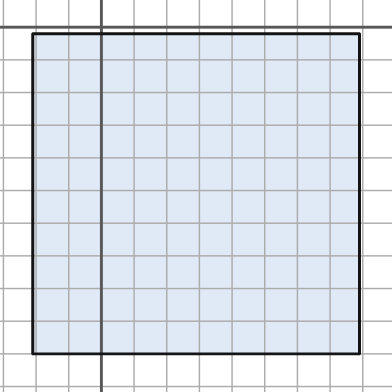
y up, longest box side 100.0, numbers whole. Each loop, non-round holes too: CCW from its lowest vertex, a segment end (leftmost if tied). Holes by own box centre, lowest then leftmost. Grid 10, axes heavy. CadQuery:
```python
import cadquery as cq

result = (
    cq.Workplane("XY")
    .moveTo(-21.0, -100.0)
    .lineTo(79.0, -100.0)
    .lineTo(79.0, -2.0)
    .lineTo(-21.0, -2.0)
    .close()
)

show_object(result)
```